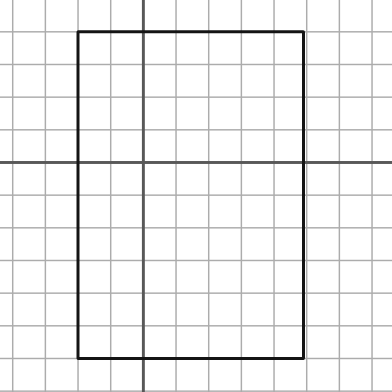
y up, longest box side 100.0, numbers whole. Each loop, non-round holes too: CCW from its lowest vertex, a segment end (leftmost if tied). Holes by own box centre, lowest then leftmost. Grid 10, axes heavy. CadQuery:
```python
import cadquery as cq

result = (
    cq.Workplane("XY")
    .moveTo(-20.0, -60.0)
    .lineTo(49.0, -60.0)
    .lineTo(49.0, 40.0)
    .lineTo(-20.0, 40.0)
    .close()
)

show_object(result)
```